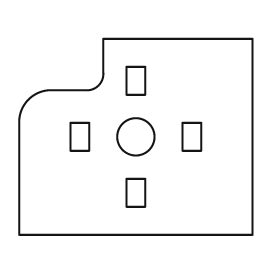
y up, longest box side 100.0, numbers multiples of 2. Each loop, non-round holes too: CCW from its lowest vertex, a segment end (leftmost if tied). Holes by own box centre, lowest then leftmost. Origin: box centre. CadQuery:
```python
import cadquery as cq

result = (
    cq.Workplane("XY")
    .moveTo(-50.0, -42.0)
    .lineTo(50.0, -42.0)
    .lineTo(50.0, 42.0)
    .lineTo(-14.0, 42.0)
    .lineTo(-14.0, 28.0)
    .threePointArc((-16.0, 22.0), (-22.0, 20.0))
    .lineTo(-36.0, 20.0)
    .threePointArc((-46.0, 16.0), (-50.0, 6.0))
    .close()
    .moveTo(-4.0, -30.0)
    .lineTo(4.0, -30.0)
    .lineTo(4.0, -18.0)
    .lineTo(-4.0, -18.0)
    .close()
    .moveTo(-28.0, -6.0)
    .lineTo(-20.0, -6.0)
    .lineTo(-20.0, 6.0)
    .lineTo(-28.0, 6.0)
    .close()
    .moveTo(0.0, 0.0)
    .circle(8.0)
    .moveTo(20.0, -6.0)
    .lineTo(28.0, -6.0)
    .lineTo(28.0, 6.0)
    .lineTo(20.0, 6.0)
    .close()
    .moveTo(-4.0, 18.0)
    .lineTo(4.0, 18.0)
    .lineTo(4.0, 30.0)
    .lineTo(-4.0, 30.0)
    .close()
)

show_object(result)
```